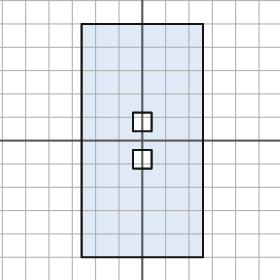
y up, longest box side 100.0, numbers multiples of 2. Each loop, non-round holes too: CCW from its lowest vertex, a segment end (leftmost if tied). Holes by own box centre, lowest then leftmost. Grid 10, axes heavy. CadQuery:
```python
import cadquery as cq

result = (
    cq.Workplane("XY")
    .moveTo(-26.0, -50.0)
    .lineTo(26.0, -50.0)
    .lineTo(26.0, 50.0)
    .lineTo(-26.0, 50.0)
    .close()
    .moveTo(-4.0, -12.0)
    .lineTo(4.0, -12.0)
    .lineTo(4.0, -4.0)
    .lineTo(-4.0, -4.0)
    .close()
    .moveTo(-4.0, 4.0)
    .lineTo(4.0, 4.0)
    .lineTo(4.0, 12.0)
    .lineTo(-4.0, 12.0)
    .close()
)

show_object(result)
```